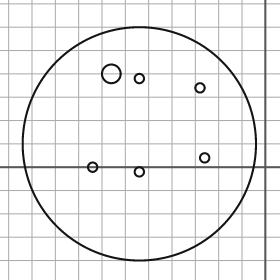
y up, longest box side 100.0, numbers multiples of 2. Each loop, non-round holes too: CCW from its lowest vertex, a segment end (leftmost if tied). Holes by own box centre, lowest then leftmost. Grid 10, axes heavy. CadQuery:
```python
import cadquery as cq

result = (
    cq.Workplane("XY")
    .moveTo(-54.0, 10.0)
    .circle(50.0)
    .moveTo(-54.0, -2.0)
    .circle(2.0)
    .moveTo(-74.0, 0.0)
    .circle(2.0)
    .moveTo(-26.0, 4.0)
    .circle(2.0)
    .moveTo(-28.0, 34.0)
    .circle(2.0)
    .moveTo(-54.0, 38.0)
    .circle(2.0)
    .moveTo(-66.0, 40.0)
    .circle(4.0)
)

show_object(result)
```